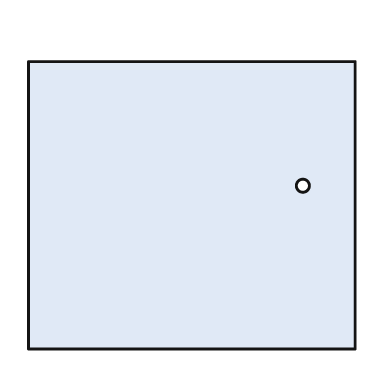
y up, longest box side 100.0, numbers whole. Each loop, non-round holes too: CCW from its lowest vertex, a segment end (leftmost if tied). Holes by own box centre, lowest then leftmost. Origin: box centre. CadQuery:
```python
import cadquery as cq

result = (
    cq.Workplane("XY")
    .moveTo(-50.0, -44.0)
    .lineTo(50.0, -44.0)
    .lineTo(50.0, 44.0)
    .lineTo(-50.0, 44.0)
    .close()
    .moveTo(34.0, 6.0)
    .circle(2.0)
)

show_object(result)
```